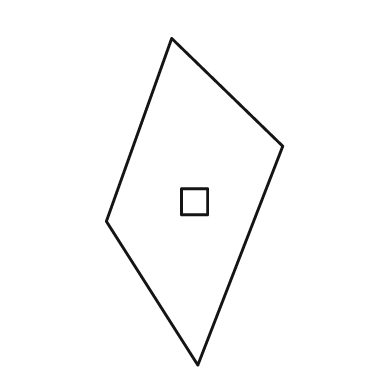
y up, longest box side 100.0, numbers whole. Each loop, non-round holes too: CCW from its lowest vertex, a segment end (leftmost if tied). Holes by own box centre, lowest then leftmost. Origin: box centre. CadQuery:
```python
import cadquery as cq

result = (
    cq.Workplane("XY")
    .moveTo(1.0, -50.0)
    .lineTo(27.0, 17.0)
    .lineTo(-7.0, 50.0)
    .lineTo(-27.0, -6.0)
    .close()
    .moveTo(-4.0, -4.0)
    .lineTo(4.0, -4.0)
    .lineTo(4.0, 4.0)
    .lineTo(-4.0, 4.0)
    .close()
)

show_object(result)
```